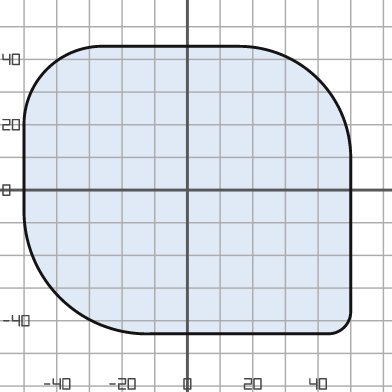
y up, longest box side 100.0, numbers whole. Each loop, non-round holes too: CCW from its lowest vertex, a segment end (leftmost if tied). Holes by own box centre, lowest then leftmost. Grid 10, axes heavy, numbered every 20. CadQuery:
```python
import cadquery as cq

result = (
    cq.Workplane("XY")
    .moveTo(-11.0, -44.0)
    .lineTo(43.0, -44.0)
    .threePointArc((48.0, -42.0), (50.0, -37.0))
    .lineTo(50.0, 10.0)
    .threePointArc((40.0, 34.0), (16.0, 44.0))
    .lineTo(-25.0, 44.0)
    .threePointArc((-43.0, 37.0), (-50.0, 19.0))
    .lineTo(-50.0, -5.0)
    .threePointArc((-39.0, -33.0), (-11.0, -44.0))
    .close()
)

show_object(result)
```